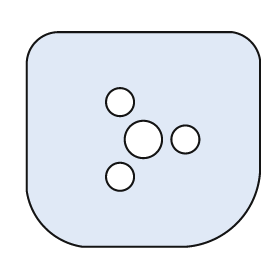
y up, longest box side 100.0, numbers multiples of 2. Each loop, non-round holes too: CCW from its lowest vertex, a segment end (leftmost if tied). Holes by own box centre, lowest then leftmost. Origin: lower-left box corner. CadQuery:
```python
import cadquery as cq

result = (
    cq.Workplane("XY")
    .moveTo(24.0, 0.0)
    .lineTo(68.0, 0.0)
    .threePointArc((90.0, 10.0), (100.0, 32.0))
    .lineTo(100.0, 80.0)
    .threePointArc((96.0, 88.0), (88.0, 92.0))
    .lineTo(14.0, 92.0)
    .threePointArc((4.0, 88.0), (0.0, 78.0))
    .lineTo(0.0, 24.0)
    .threePointArc((8.0, 8.0), (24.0, 0.0))
    .close()
    .moveTo(40.0, 30.0)
    .circle(6.0)
    .moveTo(50.0, 46.0)
    .circle(8.0)
    .moveTo(68.0, 46.0)
    .circle(6.0)
    .moveTo(40.0, 62.0)
    .circle(6.0)
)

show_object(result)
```